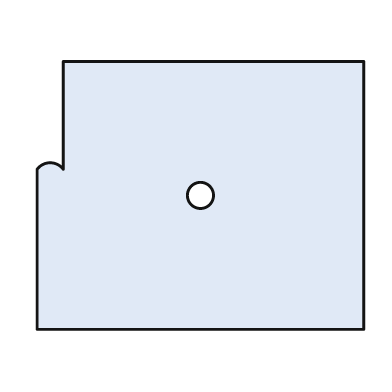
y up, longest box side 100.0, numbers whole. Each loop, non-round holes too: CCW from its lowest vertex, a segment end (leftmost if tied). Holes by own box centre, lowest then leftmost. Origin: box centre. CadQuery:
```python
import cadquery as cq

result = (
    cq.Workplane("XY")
    .moveTo(-50.0, -41.0)
    .lineTo(50.0, -41.0)
    .lineTo(50.0, 41.0)
    .lineTo(-42.0, 41.0)
    .lineTo(-42.0, 8.0)
    .threePointArc((-46.0, 10.0), (-50.0, 8.0))
    .close()
    .moveTo(0.0, 0.0)
    .circle(4.0)
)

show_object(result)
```